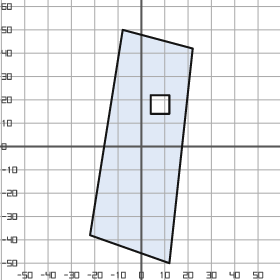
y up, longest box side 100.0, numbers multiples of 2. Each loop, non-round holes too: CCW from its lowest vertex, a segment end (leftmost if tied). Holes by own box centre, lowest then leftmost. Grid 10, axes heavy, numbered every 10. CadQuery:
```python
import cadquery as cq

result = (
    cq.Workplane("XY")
    .moveTo(12.0, -50.0)
    .lineTo(22.0, 42.0)
    .lineTo(-8.0, 50.0)
    .lineTo(-22.0, -38.0)
    .close()
    .moveTo(4.0, 14.0)
    .lineTo(12.0, 14.0)
    .lineTo(12.0, 22.0)
    .lineTo(4.0, 22.0)
    .close()
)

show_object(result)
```